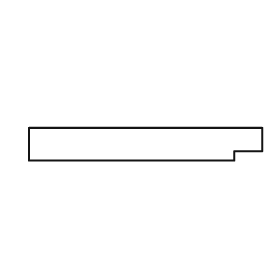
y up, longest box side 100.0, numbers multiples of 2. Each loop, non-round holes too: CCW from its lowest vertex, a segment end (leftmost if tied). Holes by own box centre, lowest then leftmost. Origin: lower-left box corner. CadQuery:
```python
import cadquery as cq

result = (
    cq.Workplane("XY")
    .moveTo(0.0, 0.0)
    .lineTo(88.0, 0.0)
    .lineTo(88.0, 4.0)
    .lineTo(100.0, 4.0)
    .lineTo(100.0, 14.0)
    .lineTo(0.0, 14.0)
    .close()
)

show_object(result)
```